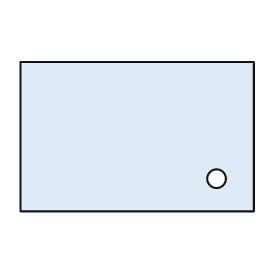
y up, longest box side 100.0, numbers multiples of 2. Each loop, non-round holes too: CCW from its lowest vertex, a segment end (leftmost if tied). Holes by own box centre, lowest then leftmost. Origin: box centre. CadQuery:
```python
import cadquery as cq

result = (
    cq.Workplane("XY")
    .moveTo(-50.0, -32.0)
    .lineTo(50.0, -32.0)
    .lineTo(50.0, 32.0)
    .lineTo(-50.0, 32.0)
    .close()
    .moveTo(34.0, -18.0)
    .circle(4.0)
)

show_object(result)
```